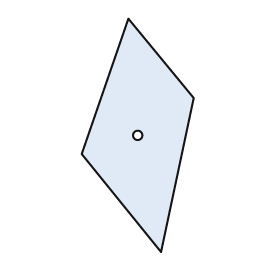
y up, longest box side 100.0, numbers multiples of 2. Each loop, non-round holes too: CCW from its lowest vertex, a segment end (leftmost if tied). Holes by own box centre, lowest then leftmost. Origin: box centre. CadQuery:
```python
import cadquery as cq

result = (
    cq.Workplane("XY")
    .moveTo(10.0, -50.0)
    .lineTo(24.0, 16.0)
    .lineTo(-4.0, 50.0)
    .lineTo(-24.0, -8.0)
    .close()
    .moveTo(0.0, 0.0)
    .circle(2.0)
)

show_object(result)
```